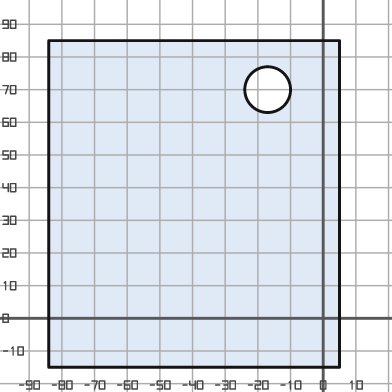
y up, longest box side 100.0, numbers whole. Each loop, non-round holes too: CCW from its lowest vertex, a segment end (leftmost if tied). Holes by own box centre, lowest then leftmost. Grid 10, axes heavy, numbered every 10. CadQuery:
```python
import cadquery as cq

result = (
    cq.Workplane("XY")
    .moveTo(-84.0, -15.0)
    .lineTo(5.0, -15.0)
    .lineTo(5.0, 85.0)
    .lineTo(-84.0, 85.0)
    .close()
    .moveTo(-17.0, 70.0)
    .circle(7.0)
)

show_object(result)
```